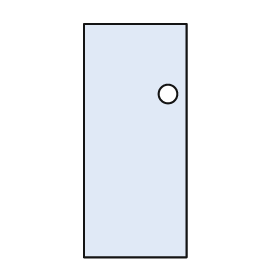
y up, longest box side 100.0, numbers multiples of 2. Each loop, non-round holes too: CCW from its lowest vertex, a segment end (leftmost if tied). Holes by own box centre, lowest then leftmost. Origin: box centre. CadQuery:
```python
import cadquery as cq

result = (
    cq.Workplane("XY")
    .moveTo(-22.0, -50.0)
    .lineTo(22.0, -50.0)
    .lineTo(22.0, 50.0)
    .lineTo(-22.0, 50.0)
    .close()
    .moveTo(14.0, 20.0)
    .circle(4.0)
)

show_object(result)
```